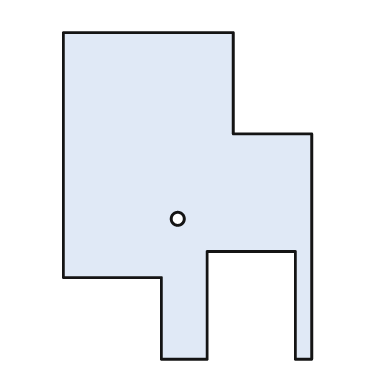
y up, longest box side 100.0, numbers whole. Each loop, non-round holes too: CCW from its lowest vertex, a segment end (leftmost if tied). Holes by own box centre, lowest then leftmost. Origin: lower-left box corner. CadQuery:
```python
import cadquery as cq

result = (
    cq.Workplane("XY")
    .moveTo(30.0, 0.0)
    .lineTo(44.0, 0.0)
    .lineTo(44.0, 33.0)
    .lineTo(71.0, 33.0)
    .lineTo(71.0, 0.0)
    .lineTo(76.0, 0.0)
    .lineTo(76.0, 69.0)
    .lineTo(52.0, 69.0)
    .lineTo(52.0, 100.0)
    .lineTo(0.0, 100.0)
    .lineTo(0.0, 25.0)
    .lineTo(30.0, 25.0)
    .close()
    .moveTo(35.0, 43.0)
    .circle(2.0)
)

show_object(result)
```